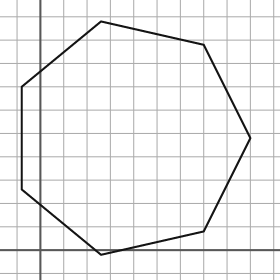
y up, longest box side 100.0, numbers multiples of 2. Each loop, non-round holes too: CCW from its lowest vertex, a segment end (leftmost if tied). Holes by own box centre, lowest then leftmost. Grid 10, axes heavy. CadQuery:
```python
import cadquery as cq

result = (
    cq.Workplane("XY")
    .moveTo(26.0, -2.0)
    .lineTo(70.0, 8.0)
    .lineTo(90.0, 48.0)
    .lineTo(70.0, 88.0)
    .lineTo(26.0, 98.0)
    .lineTo(-8.0, 70.0)
    .lineTo(-8.0, 26.0)
    .close()
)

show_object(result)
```